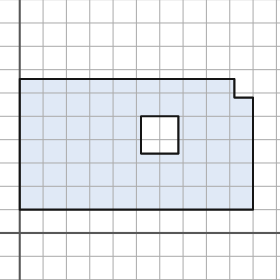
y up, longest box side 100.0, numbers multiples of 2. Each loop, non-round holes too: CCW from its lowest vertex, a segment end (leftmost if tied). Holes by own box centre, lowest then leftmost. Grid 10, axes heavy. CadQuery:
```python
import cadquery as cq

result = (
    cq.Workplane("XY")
    .moveTo(0.0, 10.0)
    .lineTo(100.0, 10.0)
    .lineTo(100.0, 58.0)
    .lineTo(92.0, 58.0)
    .lineTo(92.0, 66.0)
    .lineTo(0.0, 66.0)
    .close()
    .moveTo(52.0, 34.0)
    .lineTo(68.0, 34.0)
    .lineTo(68.0, 50.0)
    .lineTo(52.0, 50.0)
    .close()
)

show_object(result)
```